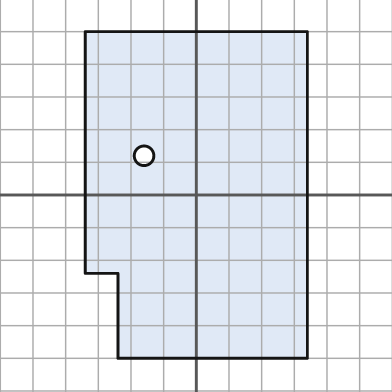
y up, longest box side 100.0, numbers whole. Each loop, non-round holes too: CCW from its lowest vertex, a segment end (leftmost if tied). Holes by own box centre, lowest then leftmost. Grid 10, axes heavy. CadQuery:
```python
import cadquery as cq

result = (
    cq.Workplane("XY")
    .moveTo(-24.0, -50.0)
    .lineTo(34.0, -50.0)
    .lineTo(34.0, 50.0)
    .lineTo(-34.0, 50.0)
    .lineTo(-34.0, -24.0)
    .lineTo(-24.0, -24.0)
    .close()
    .moveTo(-16.0, 12.0)
    .circle(3.0)
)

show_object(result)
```